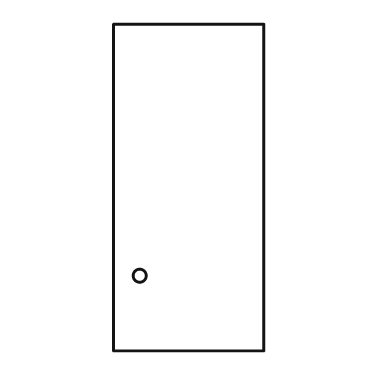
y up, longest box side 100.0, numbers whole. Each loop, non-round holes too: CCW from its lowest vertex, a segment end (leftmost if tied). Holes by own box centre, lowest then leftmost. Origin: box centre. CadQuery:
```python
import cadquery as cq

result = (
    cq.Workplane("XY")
    .moveTo(-23.0, -50.0)
    .lineTo(23.0, -50.0)
    .lineTo(23.0, 50.0)
    .lineTo(-23.0, 50.0)
    .close()
    .moveTo(-15.0, -27.0)
    .circle(2.0)
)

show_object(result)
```